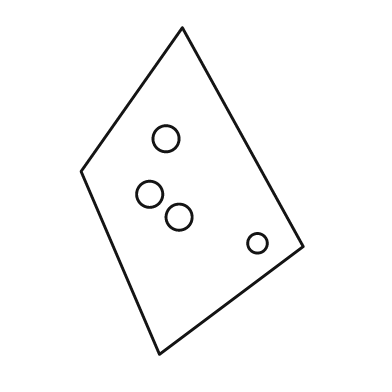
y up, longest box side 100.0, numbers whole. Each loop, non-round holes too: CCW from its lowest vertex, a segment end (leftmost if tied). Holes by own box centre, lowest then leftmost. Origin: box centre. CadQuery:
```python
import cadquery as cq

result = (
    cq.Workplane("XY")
    .moveTo(-10.0, -50.0)
    .lineTo(34.0, -17.0)
    .lineTo(-3.0, 50.0)
    .lineTo(-34.0, 6.0)
    .close()
    .moveTo(20.0, -16.0)
    .circle(3.0)
    .moveTo(-4.0, -8.0)
    .circle(4.0)
    .moveTo(-13.0, -1.0)
    .circle(4.0)
    .moveTo(-8.0, 16.0)
    .circle(4.0)
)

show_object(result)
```